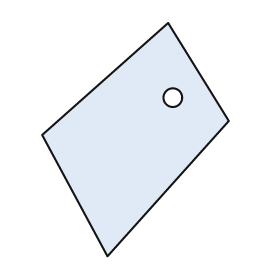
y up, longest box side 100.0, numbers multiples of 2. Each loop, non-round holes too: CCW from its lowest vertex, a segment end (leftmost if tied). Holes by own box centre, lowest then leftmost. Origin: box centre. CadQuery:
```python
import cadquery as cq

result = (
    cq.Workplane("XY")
    .moveTo(-12.0, -50.0)
    .lineTo(40.0, 8.0)
    .lineTo(14.0, 50.0)
    .lineTo(-40.0, 2.0)
    .close()
    .moveTo(16.0, 18.0)
    .circle(4.0)
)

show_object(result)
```